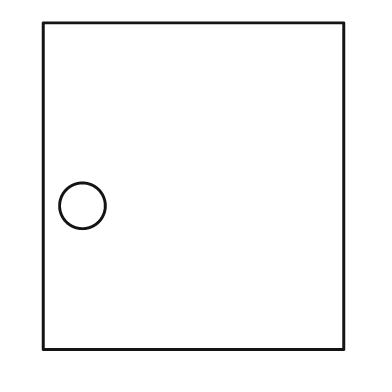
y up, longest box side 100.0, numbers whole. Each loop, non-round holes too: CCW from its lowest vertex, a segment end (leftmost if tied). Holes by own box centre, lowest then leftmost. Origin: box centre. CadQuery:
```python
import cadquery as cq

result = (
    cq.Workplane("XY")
    .moveTo(-46.0, -50.0)
    .lineTo(46.0, -50.0)
    .lineTo(46.0, 50.0)
    .lineTo(-46.0, 50.0)
    .close()
    .moveTo(-34.0, -6.0)
    .circle(7.0)
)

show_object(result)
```